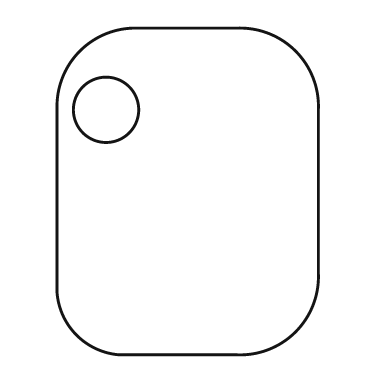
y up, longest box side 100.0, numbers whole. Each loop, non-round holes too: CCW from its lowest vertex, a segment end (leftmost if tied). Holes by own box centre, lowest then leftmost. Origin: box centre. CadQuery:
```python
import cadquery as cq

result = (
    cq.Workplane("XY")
    .moveTo(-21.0, -50.0)
    .lineTo(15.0, -50.0)
    .threePointArc((33.0, -43.0), (40.0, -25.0))
    .lineTo(40.0, 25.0)
    .threePointArc((33.0, 43.0), (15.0, 50.0))
    .lineTo(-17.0, 50.0)
    .threePointArc((-33.0, 43.0), (-40.0, 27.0))
    .lineTo(-40.0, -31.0)
    .threePointArc((-34.0, -44.0), (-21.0, -50.0))
    .close()
    .moveTo(-25.0, 25.0)
    .circle(10.0)
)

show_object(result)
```